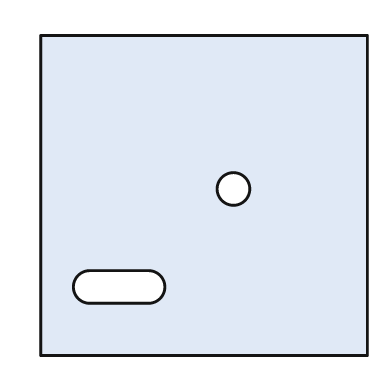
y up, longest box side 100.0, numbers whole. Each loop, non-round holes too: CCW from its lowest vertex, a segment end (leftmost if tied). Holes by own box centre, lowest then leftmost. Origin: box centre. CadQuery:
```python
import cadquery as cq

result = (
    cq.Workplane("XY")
    .moveTo(-50.0, -49.0)
    .lineTo(50.0, -49.0)
    .lineTo(50.0, 49.0)
    .lineTo(-50.0, 49.0)
    .close()
    .moveTo(-35.0, -33.0)
    .lineTo(-17.0, -33.0)
    .threePointArc((-12.0, -28.0), (-17.0, -23.0))
    .lineTo(-35.0, -23.0)
    .threePointArc((-40.0, -28.0), (-35.0, -33.0))
    .close()
    .moveTo(9.0, 2.0)
    .circle(5.0)
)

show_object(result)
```